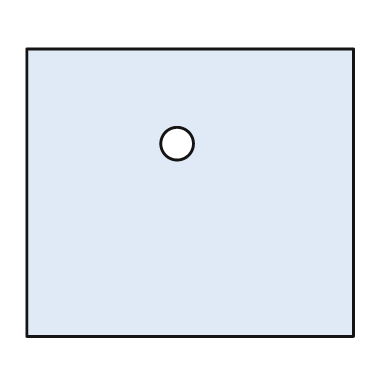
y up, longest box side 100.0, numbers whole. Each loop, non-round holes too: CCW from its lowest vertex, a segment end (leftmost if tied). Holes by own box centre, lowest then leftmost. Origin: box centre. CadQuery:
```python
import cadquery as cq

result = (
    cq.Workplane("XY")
    .moveTo(-50.0, -44.0)
    .lineTo(50.0, -44.0)
    .lineTo(50.0, 44.0)
    .lineTo(-50.0, 44.0)
    .close()
    .moveTo(-4.0, 15.0)
    .circle(5.0)
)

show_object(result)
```